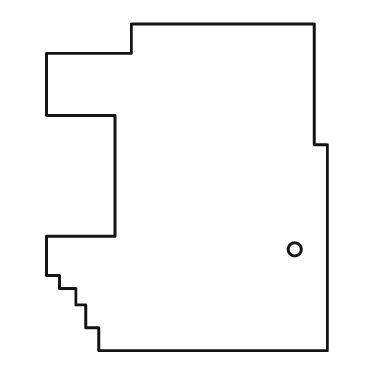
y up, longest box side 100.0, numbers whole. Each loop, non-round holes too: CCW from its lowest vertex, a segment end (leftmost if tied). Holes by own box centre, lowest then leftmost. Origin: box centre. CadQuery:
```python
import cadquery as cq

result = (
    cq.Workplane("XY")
    .moveTo(-27.0, -50.0)
    .lineTo(43.0, -50.0)
    .lineTo(43.0, 13.0)
    .lineTo(39.0, 13.0)
    .lineTo(39.0, 50.0)
    .lineTo(-17.0, 50.0)
    .lineTo(-17.0, 41.0)
    .lineTo(-43.0, 41.0)
    .lineTo(-43.0, 22.0)
    .lineTo(-22.0, 22.0)
    .lineTo(-22.0, -15.0)
    .lineTo(-43.0, -15.0)
    .lineTo(-43.0, -27.0)
    .lineTo(-39.0, -27.0)
    .lineTo(-39.0, -31.0)
    .lineTo(-34.0, -31.0)
    .lineTo(-34.0, -36.0)
    .lineTo(-31.0, -36.0)
    .lineTo(-31.0, -43.0)
    .lineTo(-27.0, -43.0)
    .close()
    .moveTo(33.0, -19.0)
    .circle(2.0)
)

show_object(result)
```